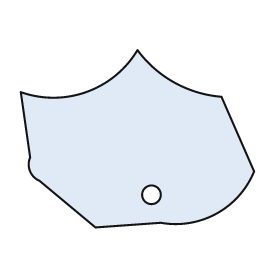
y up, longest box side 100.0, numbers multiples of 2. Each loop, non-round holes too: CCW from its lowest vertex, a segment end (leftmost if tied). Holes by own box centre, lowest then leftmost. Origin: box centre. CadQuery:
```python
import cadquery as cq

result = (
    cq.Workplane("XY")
    .moveTo(-18.0, -38.0)
    .lineTo(10.0, -36.0)
    .threePointArc((34.0, -32.0), (50.0, -14.0))
    .lineTo(36.0, 18.0)
    .threePointArc((16.0, 24.0), (0.0, 38.0))
    .threePointArc((-22.0, 20.0), (-50.0, 20.0))
    .lineTo(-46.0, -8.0)
    .threePointArc((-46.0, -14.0), (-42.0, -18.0))
    .close()
    .moveTo(6.0, -24.0)
    .circle(4.0)
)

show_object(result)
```